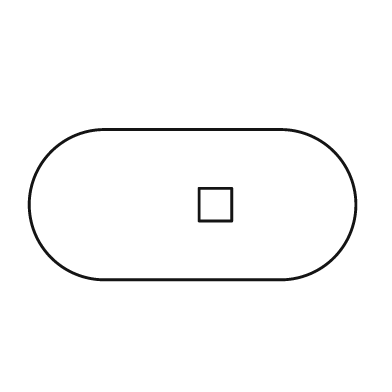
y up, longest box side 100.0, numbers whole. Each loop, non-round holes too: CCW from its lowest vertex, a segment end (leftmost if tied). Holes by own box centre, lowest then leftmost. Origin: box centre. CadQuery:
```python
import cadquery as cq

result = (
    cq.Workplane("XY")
    .moveTo(-27.0, -23.0)
    .lineTo(27.0, -23.0)
    .threePointArc((50.0, 0.0), (27.0, 23.0))
    .lineTo(-27.0, 23.0)
    .threePointArc((-50.0, 0.0), (-27.0, -23.0))
    .close()
    .moveTo(2.0, -5.0)
    .lineTo(12.0, -5.0)
    .lineTo(12.0, 5.0)
    .lineTo(2.0, 5.0)
    .close()
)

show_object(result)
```